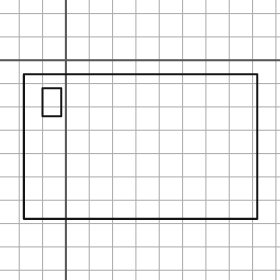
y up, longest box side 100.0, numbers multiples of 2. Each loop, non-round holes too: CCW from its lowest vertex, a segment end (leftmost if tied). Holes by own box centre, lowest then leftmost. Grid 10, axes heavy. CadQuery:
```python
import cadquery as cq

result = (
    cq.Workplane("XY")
    .moveTo(-18.0, -68.0)
    .lineTo(82.0, -68.0)
    .lineTo(82.0, -6.0)
    .lineTo(-18.0, -6.0)
    .close()
    .moveTo(-10.0, -24.0)
    .lineTo(-2.0, -24.0)
    .lineTo(-2.0, -12.0)
    .lineTo(-10.0, -12.0)
    .close()
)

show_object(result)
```